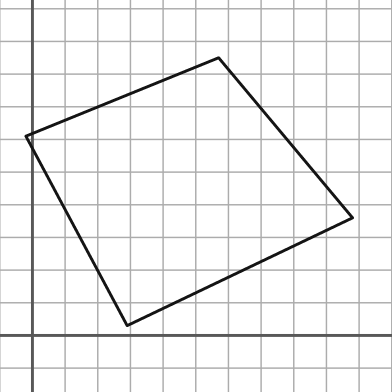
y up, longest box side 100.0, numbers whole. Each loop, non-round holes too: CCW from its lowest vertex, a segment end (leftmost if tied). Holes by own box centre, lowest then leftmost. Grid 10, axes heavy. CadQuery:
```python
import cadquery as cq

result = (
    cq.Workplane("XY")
    .moveTo(29.0, 3.0)
    .lineTo(98.0, 36.0)
    .lineTo(57.0, 85.0)
    .lineTo(-2.0, 61.0)
    .close()
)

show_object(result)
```